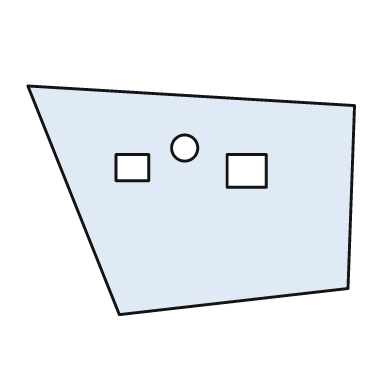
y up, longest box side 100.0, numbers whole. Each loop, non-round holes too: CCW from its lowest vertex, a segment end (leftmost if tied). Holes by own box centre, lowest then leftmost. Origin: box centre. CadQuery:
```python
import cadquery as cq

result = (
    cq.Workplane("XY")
    .moveTo(-22.0, -35.0)
    .lineTo(48.0, -27.0)
    .lineTo(50.0, 29.0)
    .lineTo(-50.0, 35.0)
    .close()
    .moveTo(11.0, 4.0)
    .lineTo(23.0, 4.0)
    .lineTo(23.0, 14.0)
    .lineTo(11.0, 14.0)
    .close()
    .moveTo(-23.0, 6.0)
    .lineTo(-13.0, 6.0)
    .lineTo(-13.0, 14.0)
    .lineTo(-23.0, 14.0)
    .close()
    .moveTo(-2.0, 16.0)
    .circle(4.0)
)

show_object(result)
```